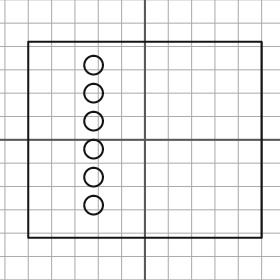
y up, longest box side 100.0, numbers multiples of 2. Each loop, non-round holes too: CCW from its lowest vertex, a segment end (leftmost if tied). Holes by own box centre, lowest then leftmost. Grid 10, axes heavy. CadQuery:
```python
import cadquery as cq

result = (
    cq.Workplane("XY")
    .moveTo(-50.0, -42.0)
    .lineTo(50.0, -42.0)
    .lineTo(50.0, 42.0)
    .lineTo(-50.0, 42.0)
    .close()
    .moveTo(-22.0, -28.0)
    .circle(4.0)
    .moveTo(-22.0, -16.0)
    .circle(4.0)
    .moveTo(-22.0, -4.0)
    .circle(4.0)
    .moveTo(-22.0, 8.0)
    .circle(4.0)
    .moveTo(-22.0, 20.0)
    .circle(4.0)
    .moveTo(-22.0, 32.0)
    .circle(4.0)
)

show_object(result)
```